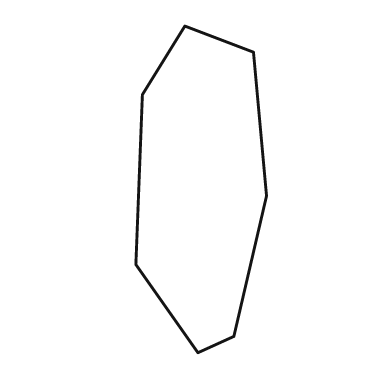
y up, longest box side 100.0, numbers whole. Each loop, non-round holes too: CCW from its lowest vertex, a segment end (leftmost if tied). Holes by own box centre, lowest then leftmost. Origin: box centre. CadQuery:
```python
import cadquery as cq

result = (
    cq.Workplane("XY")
    .moveTo(-1.0, -50.0)
    .lineTo(10.0, -45.0)
    .lineTo(20.0, -2.0)
    .lineTo(16.0, 42.0)
    .lineTo(-5.0, 50.0)
    .lineTo(-18.0, 29.0)
    .lineTo(-20.0, -23.0)
    .close()
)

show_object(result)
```